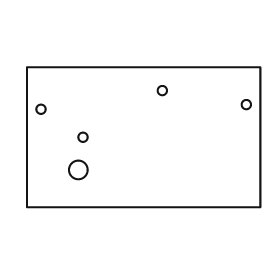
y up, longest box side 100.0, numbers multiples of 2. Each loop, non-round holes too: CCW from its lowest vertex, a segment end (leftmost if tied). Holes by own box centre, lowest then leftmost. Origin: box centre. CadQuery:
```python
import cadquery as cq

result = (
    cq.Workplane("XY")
    .moveTo(-50.0, -30.0)
    .lineTo(50.0, -30.0)
    .lineTo(50.0, 30.0)
    .lineTo(-50.0, 30.0)
    .close()
    .moveTo(-28.0, -14.0)
    .circle(4.0)
    .moveTo(-26.0, 0.0)
    .circle(2.0)
    .moveTo(-44.0, 12.0)
    .circle(2.0)
    .moveTo(44.0, 14.0)
    .circle(2.0)
    .moveTo(8.0, 20.0)
    .circle(2.0)
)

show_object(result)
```